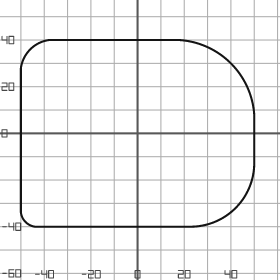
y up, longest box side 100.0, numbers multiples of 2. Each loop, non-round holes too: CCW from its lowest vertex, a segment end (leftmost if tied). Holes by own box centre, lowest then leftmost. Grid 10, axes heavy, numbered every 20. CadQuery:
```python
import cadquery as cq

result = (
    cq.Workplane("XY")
    .moveTo(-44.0, -40.0)
    .lineTo(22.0, -40.0)
    .threePointArc((42.0, -32.0), (50.0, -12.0))
    .lineTo(50.0, 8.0)
    .threePointArc((40.0, 30.0), (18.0, 40.0))
    .lineTo(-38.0, 40.0)
    .threePointArc((-46.0, 36.0), (-50.0, 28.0))
    .lineTo(-50.0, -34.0)
    .threePointArc((-48.0, -38.0), (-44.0, -40.0))
    .close()
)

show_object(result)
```